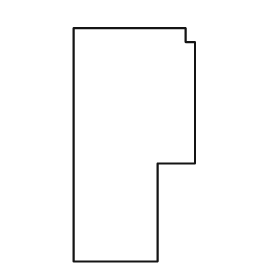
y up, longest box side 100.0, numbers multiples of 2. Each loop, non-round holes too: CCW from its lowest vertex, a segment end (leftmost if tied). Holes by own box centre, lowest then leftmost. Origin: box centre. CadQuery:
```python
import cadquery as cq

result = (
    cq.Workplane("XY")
    .moveTo(-26.0, -50.0)
    .lineTo(10.0, -50.0)
    .lineTo(10.0, -8.0)
    .lineTo(26.0, -8.0)
    .lineTo(26.0, 44.0)
    .lineTo(22.0, 44.0)
    .lineTo(22.0, 50.0)
    .lineTo(-26.0, 50.0)
    .close()
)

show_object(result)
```